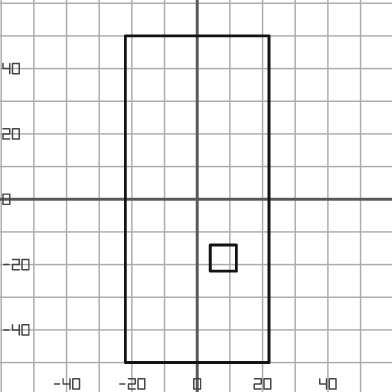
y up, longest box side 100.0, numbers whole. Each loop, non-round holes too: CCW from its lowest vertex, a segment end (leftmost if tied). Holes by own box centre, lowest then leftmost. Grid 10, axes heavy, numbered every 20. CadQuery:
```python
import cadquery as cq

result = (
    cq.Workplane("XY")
    .moveTo(-22.0, -50.0)
    .lineTo(22.0, -50.0)
    .lineTo(22.0, 50.0)
    .lineTo(-22.0, 50.0)
    .close()
    .moveTo(4.0, -22.0)
    .lineTo(12.0, -22.0)
    .lineTo(12.0, -14.0)
    .lineTo(4.0, -14.0)
    .close()
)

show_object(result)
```